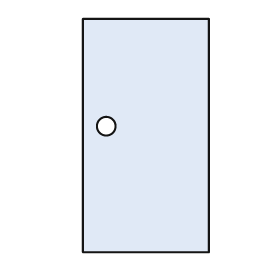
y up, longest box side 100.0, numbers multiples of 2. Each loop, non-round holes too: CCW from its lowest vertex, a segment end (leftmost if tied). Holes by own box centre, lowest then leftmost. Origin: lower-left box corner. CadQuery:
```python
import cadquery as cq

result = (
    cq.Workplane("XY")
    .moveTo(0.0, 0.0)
    .lineTo(54.0, 0.0)
    .lineTo(54.0, 100.0)
    .lineTo(0.0, 100.0)
    .close()
    .moveTo(10.0, 54.0)
    .circle(4.0)
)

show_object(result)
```